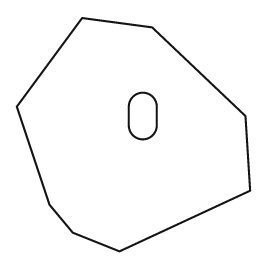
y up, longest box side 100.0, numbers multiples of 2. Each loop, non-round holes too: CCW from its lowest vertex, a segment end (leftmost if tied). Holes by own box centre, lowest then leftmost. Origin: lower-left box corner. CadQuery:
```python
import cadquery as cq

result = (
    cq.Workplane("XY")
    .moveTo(44.0, 0.0)
    .lineTo(100.0, 26.0)
    .lineTo(98.0, 58.0)
    .lineTo(58.0, 96.0)
    .lineTo(28.0, 100.0)
    .lineTo(0.0, 62.0)
    .lineTo(14.0, 20.0)
    .lineTo(24.0, 8.0)
    .close()
    .moveTo(48.0, 54.0)
    .threePointArc((54.0, 48.0), (60.0, 54.0))
    .lineTo(60.0, 62.0)
    .threePointArc((54.0, 68.0), (48.0, 62.0))
    .close()
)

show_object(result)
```